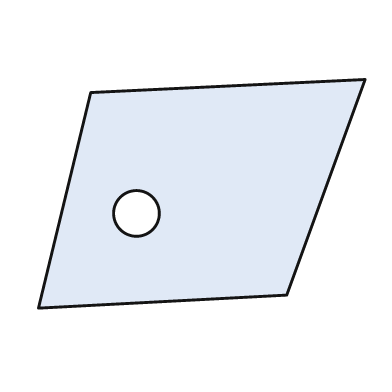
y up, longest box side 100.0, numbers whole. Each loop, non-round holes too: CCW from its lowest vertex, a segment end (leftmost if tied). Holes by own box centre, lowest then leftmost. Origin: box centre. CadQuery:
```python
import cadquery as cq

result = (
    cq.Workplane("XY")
    .moveTo(-50.0, -35.0)
    .lineTo(26.0, -31.0)
    .lineTo(50.0, 35.0)
    .lineTo(-34.0, 31.0)
    .close()
    .moveTo(-20.0, -6.0)
    .circle(7.0)
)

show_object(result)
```